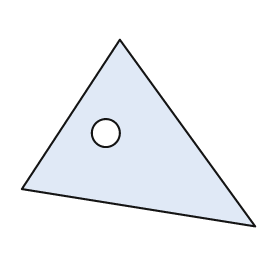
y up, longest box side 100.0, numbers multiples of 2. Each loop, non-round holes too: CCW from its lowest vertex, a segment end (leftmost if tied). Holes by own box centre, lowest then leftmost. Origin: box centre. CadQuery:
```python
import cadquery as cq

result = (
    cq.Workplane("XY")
    .moveTo(50.0, -40.0)
    .lineTo(-8.0, 40.0)
    .lineTo(-50.0, -24.0)
    .close()
    .moveTo(-14.0, 0.0)
    .circle(6.0)
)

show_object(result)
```